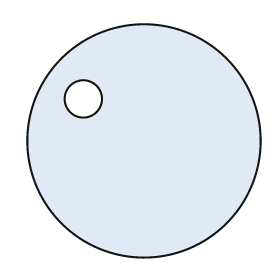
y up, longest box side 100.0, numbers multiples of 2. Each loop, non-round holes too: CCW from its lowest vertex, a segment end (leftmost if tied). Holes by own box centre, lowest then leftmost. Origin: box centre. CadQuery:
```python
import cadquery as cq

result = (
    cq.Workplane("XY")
    .moveTo(0.0, 0.0)
    .circle(50.0)
    .moveTo(-26.0, 18.0)
    .circle(8.0)
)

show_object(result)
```